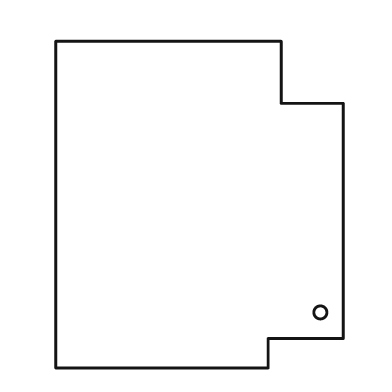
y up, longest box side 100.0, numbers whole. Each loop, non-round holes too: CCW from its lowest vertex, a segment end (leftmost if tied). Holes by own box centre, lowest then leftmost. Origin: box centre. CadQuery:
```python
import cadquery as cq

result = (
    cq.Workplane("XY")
    .moveTo(-44.0, -50.0)
    .lineTo(21.0, -50.0)
    .lineTo(21.0, -41.0)
    .lineTo(44.0, -41.0)
    .lineTo(44.0, 31.0)
    .lineTo(25.0, 31.0)
    .lineTo(25.0, 50.0)
    .lineTo(-44.0, 50.0)
    .close()
    .moveTo(37.0, -33.0)
    .circle(2.0)
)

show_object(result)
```